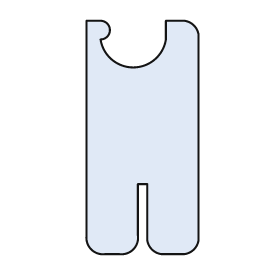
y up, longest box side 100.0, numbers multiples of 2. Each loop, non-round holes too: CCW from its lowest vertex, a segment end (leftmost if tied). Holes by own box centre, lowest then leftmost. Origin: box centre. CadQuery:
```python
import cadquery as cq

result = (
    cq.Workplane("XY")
    .moveTo(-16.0, -50.0)
    .lineTo(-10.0, -50.0)
    .threePointArc((-4.0, -48.0), (-2.0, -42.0))
    .lineTo(-2.0, -20.0)
    .lineTo(2.0, -20.0)
    .lineTo(2.0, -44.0)
    .threePointArc((4.0, -48.0), (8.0, -50.0))
    .lineTo(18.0, -50.0)
    .threePointArc((22.0, -48.0), (24.0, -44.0))
    .lineTo(24.0, 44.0)
    .threePointArc((22.0, 48.0), (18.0, 50.0))
    .lineTo(10.0, 50.0)
    .lineTo(10.0, 42.0)
    .threePointArc((-4.0, 30.0), (-18.0, 42.0))
    .threePointArc((-14.0, 46.0), (-18.0, 50.0))
    .lineTo(-24.0, 50.0)
    .lineTo(-24.0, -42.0)
    .threePointArc((-22.0, -48.0), (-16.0, -50.0))
    .close()
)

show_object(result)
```